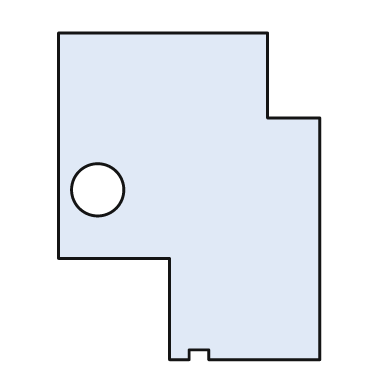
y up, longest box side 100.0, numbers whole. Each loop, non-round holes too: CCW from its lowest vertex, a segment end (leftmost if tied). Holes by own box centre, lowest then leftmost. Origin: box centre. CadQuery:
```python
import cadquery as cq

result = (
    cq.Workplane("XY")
    .moveTo(-6.0, -50.0)
    .lineTo(0.0, -50.0)
    .lineTo(0.0, -47.0)
    .lineTo(6.0, -47.0)
    .lineTo(6.0, -50.0)
    .lineTo(40.0, -50.0)
    .lineTo(40.0, 24.0)
    .lineTo(24.0, 24.0)
    .lineTo(24.0, 50.0)
    .lineTo(-40.0, 50.0)
    .lineTo(-40.0, -19.0)
    .lineTo(-6.0, -19.0)
    .close()
    .moveTo(-28.0, 2.0)
    .circle(8.0)
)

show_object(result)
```